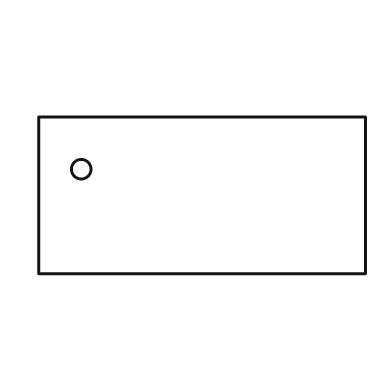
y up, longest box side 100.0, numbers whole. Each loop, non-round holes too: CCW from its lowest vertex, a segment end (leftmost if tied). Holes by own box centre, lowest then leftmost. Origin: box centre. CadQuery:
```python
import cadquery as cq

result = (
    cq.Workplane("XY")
    .moveTo(-50.0, -24.0)
    .lineTo(50.0, -24.0)
    .lineTo(50.0, 24.0)
    .lineTo(-50.0, 24.0)
    .close()
    .moveTo(-37.0, 8.0)
    .circle(3.0)
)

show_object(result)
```